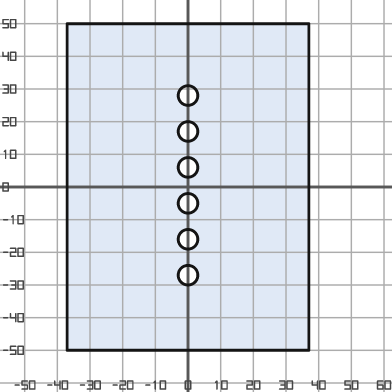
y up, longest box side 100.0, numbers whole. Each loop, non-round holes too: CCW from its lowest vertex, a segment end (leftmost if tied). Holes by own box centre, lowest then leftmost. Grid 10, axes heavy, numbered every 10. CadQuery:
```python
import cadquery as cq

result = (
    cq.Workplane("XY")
    .moveTo(-37.0, -50.0)
    .lineTo(37.0, -50.0)
    .lineTo(37.0, 50.0)
    .lineTo(-37.0, 50.0)
    .close()
    .moveTo(0.0, -27.0)
    .circle(3.0)
    .moveTo(0.0, -16.0)
    .circle(3.0)
    .moveTo(0.0, -5.0)
    .circle(3.0)
    .moveTo(0.0, 6.0)
    .circle(3.0)
    .moveTo(0.0, 17.0)
    .circle(3.0)
    .moveTo(0.0, 28.0)
    .circle(3.0)
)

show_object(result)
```